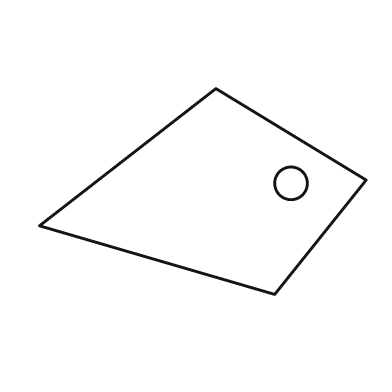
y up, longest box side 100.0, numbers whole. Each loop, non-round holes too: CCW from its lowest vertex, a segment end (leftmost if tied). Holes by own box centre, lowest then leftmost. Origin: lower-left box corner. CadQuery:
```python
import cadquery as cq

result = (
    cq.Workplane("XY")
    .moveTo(72.0, 0.0)
    .lineTo(100.0, 35.0)
    .lineTo(54.0, 63.0)
    .lineTo(0.0, 21.0)
    .close()
    .moveTo(77.0, 34.0)
    .circle(5.0)
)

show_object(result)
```